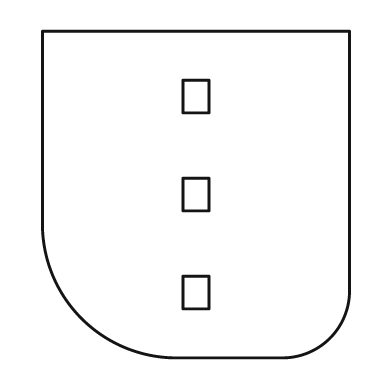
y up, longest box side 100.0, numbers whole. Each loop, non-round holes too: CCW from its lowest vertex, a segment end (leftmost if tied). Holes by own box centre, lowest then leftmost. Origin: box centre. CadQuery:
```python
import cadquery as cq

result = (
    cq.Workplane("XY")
    .moveTo(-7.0, -50.0)
    .lineTo(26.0, -50.0)
    .threePointArc((41.0, -44.0), (47.0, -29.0))
    .lineTo(47.0, 50.0)
    .lineTo(-47.0, 50.0)
    .lineTo(-47.0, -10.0)
    .threePointArc((-35.0, -38.0), (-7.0, -50.0))
    .close()
    .moveTo(-4.0, -35.0)
    .lineTo(4.0, -35.0)
    .lineTo(4.0, -25.0)
    .lineTo(-4.0, -25.0)
    .close()
    .moveTo(-4.0, -5.0)
    .lineTo(4.0, -5.0)
    .lineTo(4.0, 5.0)
    .lineTo(-4.0, 5.0)
    .close()
    .moveTo(-4.0, 25.0)
    .lineTo(4.0, 25.0)
    .lineTo(4.0, 35.0)
    .lineTo(-4.0, 35.0)
    .close()
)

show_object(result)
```